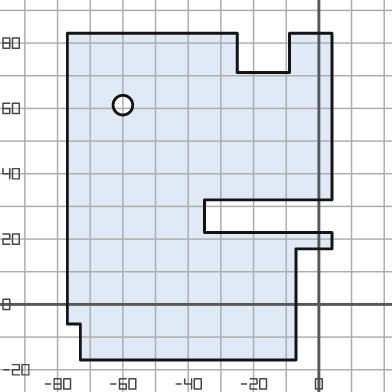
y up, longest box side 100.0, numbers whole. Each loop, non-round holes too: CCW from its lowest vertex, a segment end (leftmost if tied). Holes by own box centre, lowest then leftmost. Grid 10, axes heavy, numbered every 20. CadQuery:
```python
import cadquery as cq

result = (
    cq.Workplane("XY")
    .moveTo(-73.0, -17.0)
    .lineTo(-7.0, -17.0)
    .lineTo(-7.0, 17.0)
    .lineTo(4.0, 17.0)
    .lineTo(4.0, 22.0)
    .lineTo(-35.0, 22.0)
    .lineTo(-35.0, 32.0)
    .lineTo(4.0, 32.0)
    .lineTo(4.0, 83.0)
    .lineTo(-9.0, 83.0)
    .lineTo(-9.0, 71.0)
    .lineTo(-25.0, 71.0)
    .lineTo(-25.0, 83.0)
    .lineTo(-77.0, 83.0)
    .lineTo(-77.0, -6.0)
    .lineTo(-73.0, -6.0)
    .close()
    .moveTo(-60.0, 61.0)
    .circle(3.0)
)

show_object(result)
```